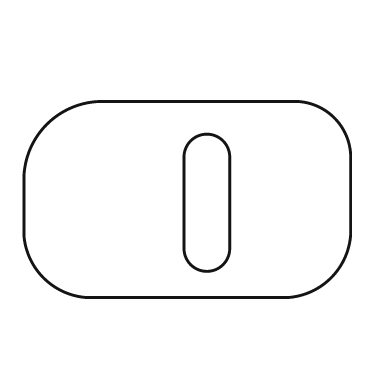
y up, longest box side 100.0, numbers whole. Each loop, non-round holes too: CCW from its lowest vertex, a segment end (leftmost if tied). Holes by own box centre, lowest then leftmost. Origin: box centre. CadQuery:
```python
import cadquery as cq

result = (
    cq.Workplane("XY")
    .moveTo(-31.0, -30.0)
    .lineTo(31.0, -30.0)
    .threePointArc((44.0, -24.0), (50.0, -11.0))
    .lineTo(50.0, 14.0)
    .threePointArc((45.0, 25.0), (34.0, 30.0))
    .lineTo(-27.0, 30.0)
    .threePointArc((-43.0, 23.0), (-50.0, 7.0))
    .lineTo(-50.0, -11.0)
    .threePointArc((-44.0, -24.0), (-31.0, -30.0))
    .close()
    .moveTo(-1.0, -15.0)
    .threePointArc((6.0, -22.0), (13.0, -15.0))
    .lineTo(13.0, 13.0)
    .threePointArc((6.0, 20.0), (-1.0, 13.0))
    .close()
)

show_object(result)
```